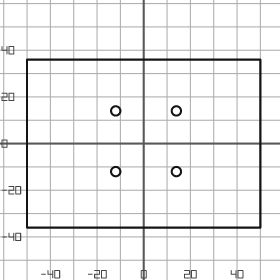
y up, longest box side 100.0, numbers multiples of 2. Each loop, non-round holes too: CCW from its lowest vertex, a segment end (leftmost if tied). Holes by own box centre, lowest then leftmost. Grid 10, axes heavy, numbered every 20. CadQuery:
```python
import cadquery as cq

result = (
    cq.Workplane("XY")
    .moveTo(-50.0, -36.0)
    .lineTo(50.0, -36.0)
    .lineTo(50.0, 36.0)
    .lineTo(-50.0, 36.0)
    .close()
    .moveTo(-12.0, -12.0)
    .circle(2.0)
    .moveTo(14.0, -12.0)
    .circle(2.0)
    .moveTo(-12.0, 14.0)
    .circle(2.0)
    .moveTo(14.0, 14.0)
    .circle(2.0)
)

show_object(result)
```